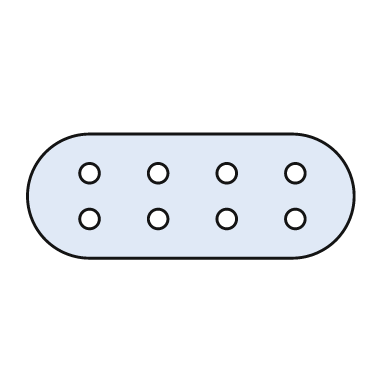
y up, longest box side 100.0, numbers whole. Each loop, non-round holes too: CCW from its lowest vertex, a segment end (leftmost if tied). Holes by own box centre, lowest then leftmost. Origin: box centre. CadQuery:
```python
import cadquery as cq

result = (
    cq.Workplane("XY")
    .moveTo(-31.0, -19.0)
    .lineTo(31.0, -19.0)
    .threePointArc((50.0, 0.0), (31.0, 19.0))
    .lineTo(-31.0, 19.0)
    .threePointArc((-50.0, 0.0), (-31.0, -19.0))
    .close()
    .moveTo(-31.0, -7.0)
    .circle(3.0)
    .moveTo(-10.0, -7.0)
    .circle(3.0)
    .moveTo(11.0, -7.0)
    .circle(3.0)
    .moveTo(32.0, -7.0)
    .circle(3.0)
    .moveTo(-31.0, 7.0)
    .circle(3.0)
    .moveTo(-10.0, 7.0)
    .circle(3.0)
    .moveTo(11.0, 7.0)
    .circle(3.0)
    .moveTo(32.0, 7.0)
    .circle(3.0)
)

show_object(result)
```